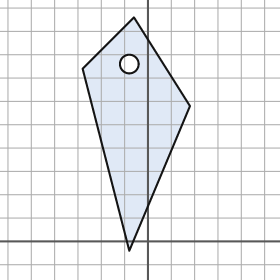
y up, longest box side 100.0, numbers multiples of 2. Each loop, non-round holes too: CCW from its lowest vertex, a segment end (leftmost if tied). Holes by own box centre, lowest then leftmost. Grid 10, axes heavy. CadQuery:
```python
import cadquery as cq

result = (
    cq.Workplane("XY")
    .moveTo(-8.0, -4.0)
    .lineTo(18.0, 58.0)
    .lineTo(-6.0, 96.0)
    .lineTo(-28.0, 74.0)
    .close()
    .moveTo(-8.0, 76.0)
    .circle(4.0)
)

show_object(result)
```